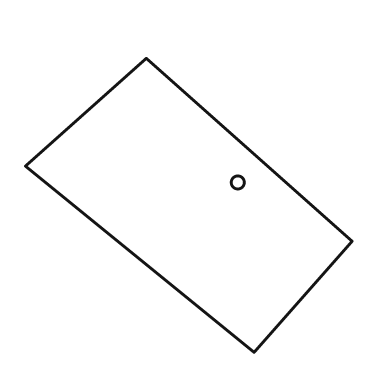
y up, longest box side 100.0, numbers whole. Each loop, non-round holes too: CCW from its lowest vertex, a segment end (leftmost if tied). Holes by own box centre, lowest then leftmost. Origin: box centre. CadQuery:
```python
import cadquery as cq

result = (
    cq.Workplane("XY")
    .moveTo(20.0, -45.0)
    .lineTo(50.0, -11.0)
    .lineTo(-13.0, 45.0)
    .lineTo(-50.0, 12.0)
    .close()
    .moveTo(15.0, 7.0)
    .circle(2.0)
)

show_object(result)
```